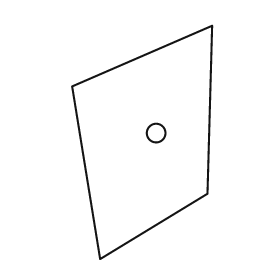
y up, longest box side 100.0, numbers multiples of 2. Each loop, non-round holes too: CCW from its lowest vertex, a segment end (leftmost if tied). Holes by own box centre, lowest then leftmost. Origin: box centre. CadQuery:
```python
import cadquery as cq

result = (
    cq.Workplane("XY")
    .moveTo(-18.0, -50.0)
    .lineTo(28.0, -22.0)
    .lineTo(30.0, 50.0)
    .lineTo(-30.0, 24.0)
    .close()
    .moveTo(6.0, 4.0)
    .circle(4.0)
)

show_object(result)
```